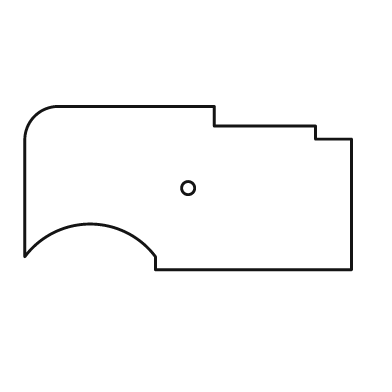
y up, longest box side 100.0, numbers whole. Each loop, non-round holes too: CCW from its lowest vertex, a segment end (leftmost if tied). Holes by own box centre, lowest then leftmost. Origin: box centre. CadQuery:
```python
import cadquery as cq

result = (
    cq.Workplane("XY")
    .moveTo(-10.0, -25.0)
    .lineTo(50.0, -25.0)
    .lineTo(50.0, 15.0)
    .lineTo(39.0, 15.0)
    .lineTo(39.0, 19.0)
    .lineTo(8.0, 19.0)
    .lineTo(8.0, 25.0)
    .lineTo(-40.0, 25.0)
    .threePointArc((-47.0, 22.0), (-50.0, 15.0))
    .lineTo(-50.0, -21.0)
    .threePointArc((-30.0, -11.0), (-10.0, -21.0))
    .close()
    .moveTo(0.0, 0.0)
    .circle(2.0)
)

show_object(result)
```